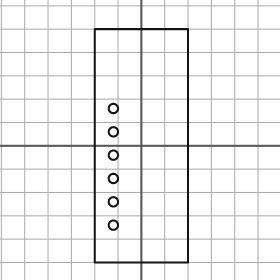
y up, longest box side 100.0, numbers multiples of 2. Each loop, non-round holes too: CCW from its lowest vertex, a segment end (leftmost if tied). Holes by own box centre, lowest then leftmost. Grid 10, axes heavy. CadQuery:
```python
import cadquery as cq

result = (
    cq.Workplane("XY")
    .moveTo(-20.0, -50.0)
    .lineTo(20.0, -50.0)
    .lineTo(20.0, 50.0)
    .lineTo(-20.0, 50.0)
    .close()
    .moveTo(-12.0, -34.0)
    .circle(2.0)
    .moveTo(-12.0, -24.0)
    .circle(2.0)
    .moveTo(-12.0, -14.0)
    .circle(2.0)
    .moveTo(-12.0, -4.0)
    .circle(2.0)
    .moveTo(-12.0, 6.0)
    .circle(2.0)
    .moveTo(-12.0, 16.0)
    .circle(2.0)
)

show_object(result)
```